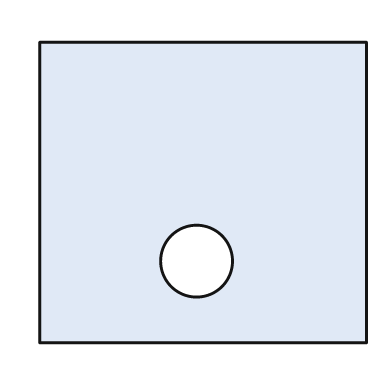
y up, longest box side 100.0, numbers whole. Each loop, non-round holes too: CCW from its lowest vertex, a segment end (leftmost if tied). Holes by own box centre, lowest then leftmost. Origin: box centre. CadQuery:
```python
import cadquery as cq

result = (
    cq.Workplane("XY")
    .moveTo(-50.0, -46.0)
    .lineTo(50.0, -46.0)
    .lineTo(50.0, 46.0)
    .lineTo(-50.0, 46.0)
    .close()
    .moveTo(-2.0, -21.0)
    .circle(11.0)
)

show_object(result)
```